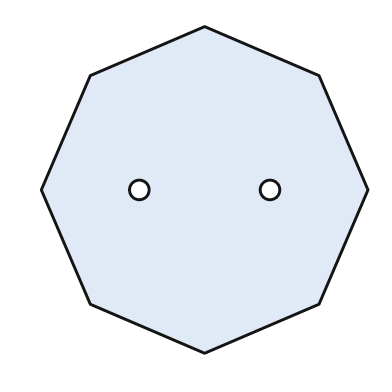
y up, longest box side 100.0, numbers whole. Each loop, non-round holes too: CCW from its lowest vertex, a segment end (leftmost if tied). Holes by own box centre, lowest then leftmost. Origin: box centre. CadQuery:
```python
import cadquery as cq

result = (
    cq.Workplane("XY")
    .moveTo(0.0, -50.0)
    .lineTo(35.0, -35.0)
    .lineTo(50.0, 0.0)
    .lineTo(35.0, 35.0)
    .lineTo(0.0, 50.0)
    .lineTo(-35.0, 35.0)
    .lineTo(-50.0, 0.0)
    .lineTo(-35.0, -35.0)
    .close()
    .moveTo(-20.0, 0.0)
    .circle(3.0)
    .moveTo(20.0, 0.0)
    .circle(3.0)
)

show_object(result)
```